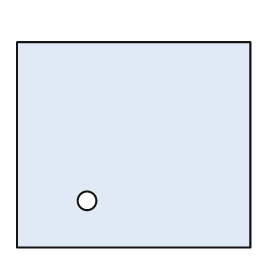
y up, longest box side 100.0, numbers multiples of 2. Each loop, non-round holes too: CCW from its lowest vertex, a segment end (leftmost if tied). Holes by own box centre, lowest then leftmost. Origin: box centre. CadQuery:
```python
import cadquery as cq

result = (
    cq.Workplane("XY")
    .moveTo(-50.0, -44.0)
    .lineTo(50.0, -44.0)
    .lineTo(50.0, 44.0)
    .lineTo(-50.0, 44.0)
    .close()
    .moveTo(-20.0, -24.0)
    .circle(4.0)
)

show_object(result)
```